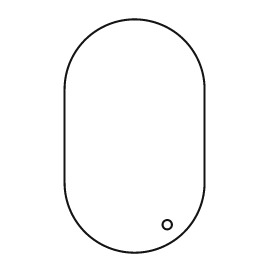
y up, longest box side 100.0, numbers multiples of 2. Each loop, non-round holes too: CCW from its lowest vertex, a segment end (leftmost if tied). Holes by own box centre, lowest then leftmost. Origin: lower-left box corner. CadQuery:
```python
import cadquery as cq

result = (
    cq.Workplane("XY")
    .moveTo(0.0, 30.0)
    .threePointArc((30.0, 0.0), (60.0, 30.0))
    .lineTo(60.0, 70.0)
    .threePointArc((30.0, 100.0), (0.0, 70.0))
    .close()
    .moveTo(44.0, 12.0)
    .circle(2.0)
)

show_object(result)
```